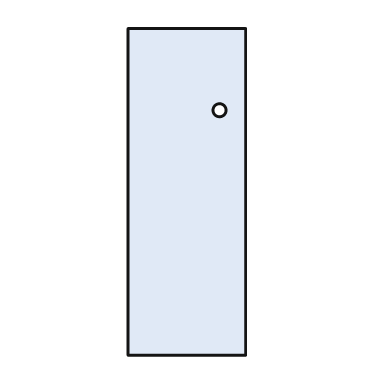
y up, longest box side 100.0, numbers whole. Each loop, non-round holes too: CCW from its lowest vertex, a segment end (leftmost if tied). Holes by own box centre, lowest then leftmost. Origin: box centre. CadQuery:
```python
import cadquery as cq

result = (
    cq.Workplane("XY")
    .moveTo(-18.0, -50.0)
    .lineTo(18.0, -50.0)
    .lineTo(18.0, 50.0)
    .lineTo(-18.0, 50.0)
    .close()
    .moveTo(10.0, 25.0)
    .circle(2.0)
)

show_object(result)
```